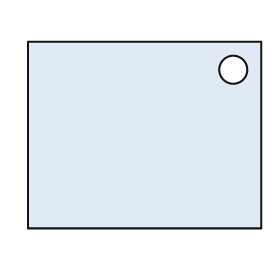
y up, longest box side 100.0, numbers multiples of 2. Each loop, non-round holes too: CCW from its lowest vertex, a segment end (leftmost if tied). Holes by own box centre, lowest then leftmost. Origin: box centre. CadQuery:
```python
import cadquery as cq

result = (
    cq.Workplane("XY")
    .moveTo(-50.0, -40.0)
    .lineTo(50.0, -40.0)
    .lineTo(50.0, 40.0)
    .lineTo(-50.0, 40.0)
    .close()
    .moveTo(38.0, 28.0)
    .circle(6.0)
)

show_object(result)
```